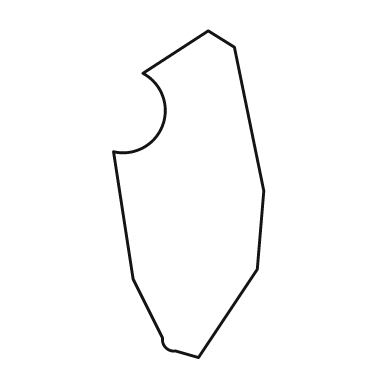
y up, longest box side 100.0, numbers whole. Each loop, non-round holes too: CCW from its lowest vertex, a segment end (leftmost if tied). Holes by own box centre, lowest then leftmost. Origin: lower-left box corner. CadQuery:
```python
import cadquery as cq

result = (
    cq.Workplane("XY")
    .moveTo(26.0, 0.0)
    .lineTo(44.0, 27.0)
    .lineTo(46.0, 51.0)
    .lineTo(37.0, 95.0)
    .lineTo(29.0, 100.0)
    .lineTo(9.0, 87.0)
    .threePointArc((15.0, 71.0), (0.0, 63.0))
    .lineTo(6.0, 24.0)
    .lineTo(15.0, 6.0)
    .threePointArc((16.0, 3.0), (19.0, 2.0))
    .close()
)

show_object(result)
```